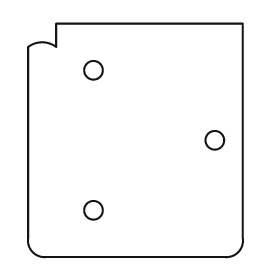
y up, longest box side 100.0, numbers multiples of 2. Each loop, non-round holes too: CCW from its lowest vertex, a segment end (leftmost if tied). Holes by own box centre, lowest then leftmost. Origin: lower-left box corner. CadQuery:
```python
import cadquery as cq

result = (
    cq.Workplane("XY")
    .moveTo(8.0, 0.0)
    .lineTo(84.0, 0.0)
    .threePointArc((90.0, 2.0), (92.0, 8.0))
    .lineTo(92.0, 100.0)
    .lineTo(12.0, 100.0)
    .lineTo(12.0, 90.0)
    .threePointArc((6.0, 92.0), (0.0, 90.0))
    .lineTo(0.0, 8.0)
    .threePointArc((2.0, 2.0), (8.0, 0.0))
    .close()
    .moveTo(28.0, 20.0)
    .circle(4.0)
    .moveTo(80.0, 50.0)
    .circle(4.0)
    .moveTo(28.0, 80.0)
    .circle(4.0)
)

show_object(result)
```